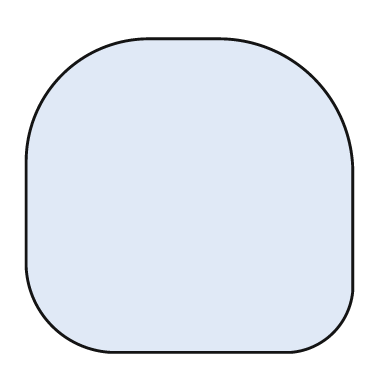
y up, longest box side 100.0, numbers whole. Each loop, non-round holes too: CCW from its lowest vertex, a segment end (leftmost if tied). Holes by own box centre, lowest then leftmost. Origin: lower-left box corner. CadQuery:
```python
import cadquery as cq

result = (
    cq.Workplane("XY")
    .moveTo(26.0, 0.0)
    .lineTo(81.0, 0.0)
    .threePointArc((94.0, 6.0), (100.0, 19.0))
    .lineTo(100.0, 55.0)
    .threePointArc((88.0, 84.0), (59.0, 96.0))
    .lineTo(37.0, 96.0)
    .threePointArc((11.0, 85.0), (0.0, 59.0))
    .lineTo(0.0, 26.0)
    .threePointArc((8.0, 8.0), (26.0, 0.0))
    .close()
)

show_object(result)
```